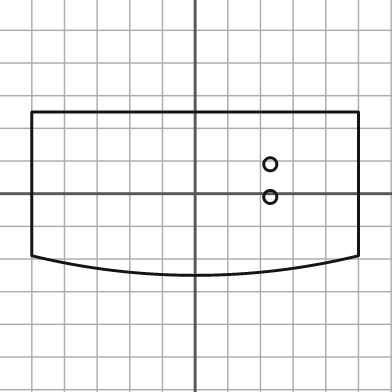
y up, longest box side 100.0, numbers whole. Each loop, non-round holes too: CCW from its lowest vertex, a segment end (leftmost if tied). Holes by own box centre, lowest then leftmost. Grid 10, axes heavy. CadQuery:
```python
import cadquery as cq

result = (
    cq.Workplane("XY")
    .moveTo(-50.0, -19.0)
    .threePointArc((0.0, -25.0), (50.0, -19.0))
    .lineTo(50.0, 25.0)
    .lineTo(-50.0, 25.0)
    .close()
    .moveTo(23.0, -1.0)
    .circle(2.0)
    .moveTo(23.0, 9.0)
    .circle(2.0)
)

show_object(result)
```